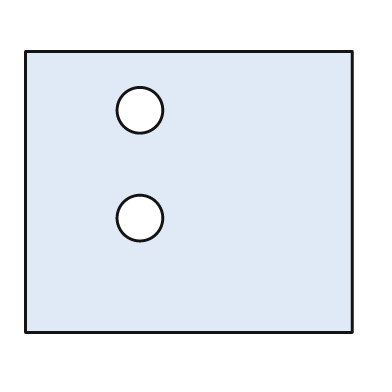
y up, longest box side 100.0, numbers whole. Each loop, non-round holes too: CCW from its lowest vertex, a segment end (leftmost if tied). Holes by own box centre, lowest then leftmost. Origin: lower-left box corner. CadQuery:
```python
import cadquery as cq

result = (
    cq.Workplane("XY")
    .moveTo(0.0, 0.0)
    .lineTo(100.0, 0.0)
    .lineTo(100.0, 86.0)
    .lineTo(0.0, 86.0)
    .close()
    .moveTo(35.0, 35.0)
    .circle(7.0)
    .moveTo(35.0, 68.0)
    .circle(7.0)
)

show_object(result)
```